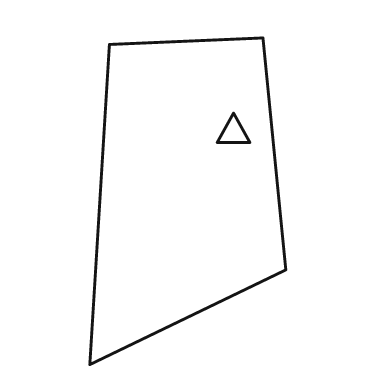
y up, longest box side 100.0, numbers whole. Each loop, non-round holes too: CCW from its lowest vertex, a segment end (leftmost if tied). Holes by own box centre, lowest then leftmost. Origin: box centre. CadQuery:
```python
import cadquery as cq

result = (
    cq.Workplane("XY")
    .moveTo(-30.0, -50.0)
    .lineTo(30.0, -21.0)
    .lineTo(23.0, 50.0)
    .lineTo(-24.0, 48.0)
    .close()
    .moveTo(9.0, 18.0)
    .lineTo(19.0, 18.0)
    .lineTo(14.0, 27.0)
    .close()
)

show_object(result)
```